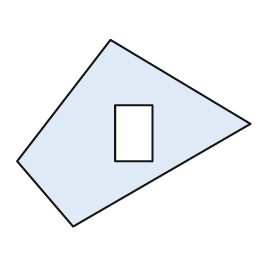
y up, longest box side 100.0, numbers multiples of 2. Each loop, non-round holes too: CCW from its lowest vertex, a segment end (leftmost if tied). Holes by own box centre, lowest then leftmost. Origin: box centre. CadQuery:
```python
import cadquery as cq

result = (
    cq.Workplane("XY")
    .moveTo(-26.0, -40.0)
    .lineTo(50.0, 4.0)
    .lineTo(-10.0, 40.0)
    .lineTo(-50.0, -12.0)
    .close()
    .moveTo(-8.0, -12.0)
    .lineTo(8.0, -12.0)
    .lineTo(8.0, 12.0)
    .lineTo(-8.0, 12.0)
    .close()
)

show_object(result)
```